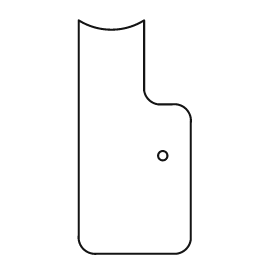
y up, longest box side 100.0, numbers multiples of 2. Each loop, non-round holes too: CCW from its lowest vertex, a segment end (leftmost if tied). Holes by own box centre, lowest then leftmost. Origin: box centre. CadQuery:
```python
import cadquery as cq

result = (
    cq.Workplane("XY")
    .moveTo(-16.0, -50.0)
    .lineTo(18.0, -50.0)
    .threePointArc((22.0, -48.0), (24.0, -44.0))
    .lineTo(24.0, 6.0)
    .threePointArc((22.0, 12.0), (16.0, 14.0))
    .lineTo(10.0, 14.0)
    .threePointArc((6.0, 16.0), (4.0, 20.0))
    .lineTo(4.0, 50.0)
    .threePointArc((-10.0, 46.0), (-24.0, 50.0))
    .lineTo(-24.0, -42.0)
    .threePointArc((-22.0, -48.0), (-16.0, -50.0))
    .close()
    .moveTo(12.0, -8.0)
    .circle(2.0)
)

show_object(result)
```